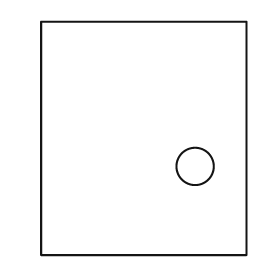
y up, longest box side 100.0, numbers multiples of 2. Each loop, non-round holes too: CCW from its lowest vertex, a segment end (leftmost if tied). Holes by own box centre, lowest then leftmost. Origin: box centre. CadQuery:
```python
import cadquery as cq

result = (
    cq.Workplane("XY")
    .moveTo(-44.0, -50.0)
    .lineTo(44.0, -50.0)
    .lineTo(44.0, 50.0)
    .lineTo(-44.0, 50.0)
    .close()
    .moveTo(22.0, -12.0)
    .circle(8.0)
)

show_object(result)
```